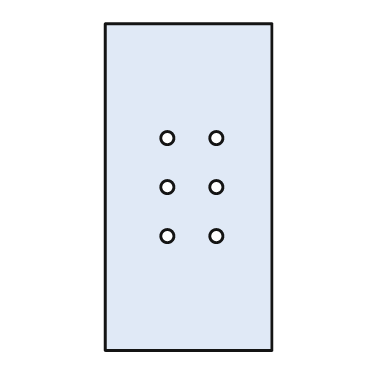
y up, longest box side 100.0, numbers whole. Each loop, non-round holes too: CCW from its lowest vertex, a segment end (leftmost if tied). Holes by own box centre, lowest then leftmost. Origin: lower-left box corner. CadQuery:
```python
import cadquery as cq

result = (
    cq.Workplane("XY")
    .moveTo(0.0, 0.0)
    .lineTo(51.0, 0.0)
    .lineTo(51.0, 100.0)
    .lineTo(0.0, 100.0)
    .close()
    .moveTo(19.0, 35.0)
    .circle(2.0)
    .moveTo(34.0, 35.0)
    .circle(2.0)
    .moveTo(19.0, 50.0)
    .circle(2.0)
    .moveTo(34.0, 50.0)
    .circle(2.0)
    .moveTo(19.0, 65.0)
    .circle(2.0)
    .moveTo(34.0, 65.0)
    .circle(2.0)
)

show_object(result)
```